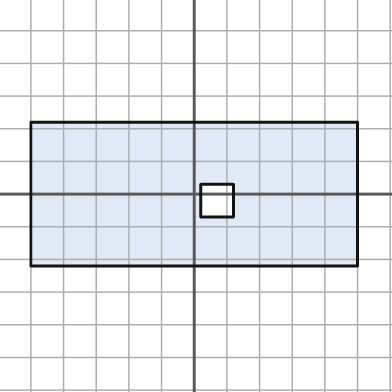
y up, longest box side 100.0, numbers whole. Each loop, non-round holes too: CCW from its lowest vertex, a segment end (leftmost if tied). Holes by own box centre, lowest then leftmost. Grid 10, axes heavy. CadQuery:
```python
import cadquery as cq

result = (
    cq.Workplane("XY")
    .moveTo(-50.0, -22.0)
    .lineTo(50.0, -22.0)
    .lineTo(50.0, 22.0)
    .lineTo(-50.0, 22.0)
    .close()
    .moveTo(2.0, -7.0)
    .lineTo(12.0, -7.0)
    .lineTo(12.0, 3.0)
    .lineTo(2.0, 3.0)
    .close()
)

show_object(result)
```